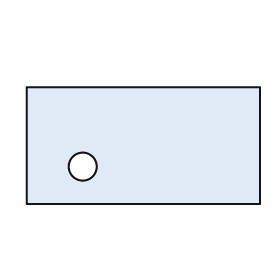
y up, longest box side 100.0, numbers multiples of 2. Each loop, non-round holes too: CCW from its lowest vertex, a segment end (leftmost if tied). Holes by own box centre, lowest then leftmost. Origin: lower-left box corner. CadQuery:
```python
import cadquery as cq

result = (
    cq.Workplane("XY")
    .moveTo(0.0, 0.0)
    .lineTo(100.0, 0.0)
    .lineTo(100.0, 50.0)
    .lineTo(0.0, 50.0)
    .close()
    .moveTo(24.0, 16.0)
    .circle(6.0)
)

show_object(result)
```